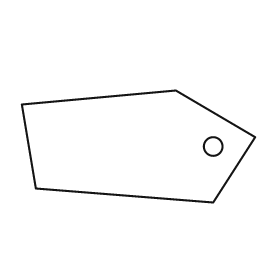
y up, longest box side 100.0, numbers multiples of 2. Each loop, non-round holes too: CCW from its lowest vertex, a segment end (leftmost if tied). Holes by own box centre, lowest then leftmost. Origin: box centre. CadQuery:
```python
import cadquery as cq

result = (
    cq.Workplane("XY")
    .moveTo(32.0, -24.0)
    .lineTo(50.0, 4.0)
    .lineTo(16.0, 24.0)
    .lineTo(-50.0, 18.0)
    .lineTo(-44.0, -18.0)
    .close()
    .moveTo(32.0, 0.0)
    .circle(4.0)
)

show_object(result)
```